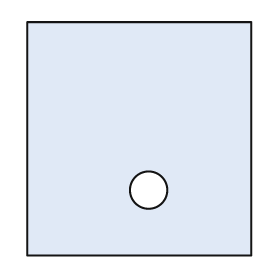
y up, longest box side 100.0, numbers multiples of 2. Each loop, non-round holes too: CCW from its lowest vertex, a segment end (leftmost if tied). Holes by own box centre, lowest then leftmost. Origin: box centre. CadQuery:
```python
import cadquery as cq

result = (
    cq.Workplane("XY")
    .moveTo(-48.0, -50.0)
    .lineTo(48.0, -50.0)
    .lineTo(48.0, 50.0)
    .lineTo(-48.0, 50.0)
    .close()
    .moveTo(4.0, -22.0)
    .circle(8.0)
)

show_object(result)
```